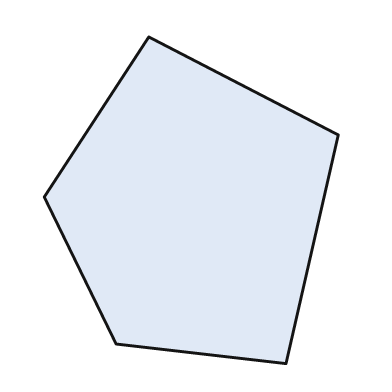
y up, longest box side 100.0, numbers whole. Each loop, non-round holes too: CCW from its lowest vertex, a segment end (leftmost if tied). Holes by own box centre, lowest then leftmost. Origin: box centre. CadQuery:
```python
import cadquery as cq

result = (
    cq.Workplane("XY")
    .moveTo(29.0, -50.0)
    .lineTo(45.0, 20.0)
    .lineTo(-13.0, 50.0)
    .lineTo(-45.0, 1.0)
    .lineTo(-23.0, -44.0)
    .close()
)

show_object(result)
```